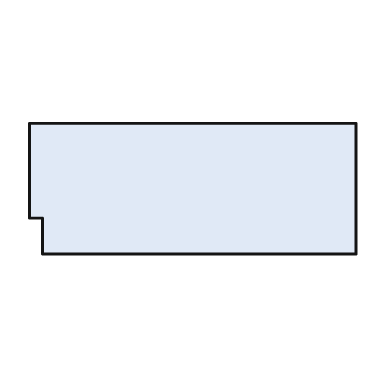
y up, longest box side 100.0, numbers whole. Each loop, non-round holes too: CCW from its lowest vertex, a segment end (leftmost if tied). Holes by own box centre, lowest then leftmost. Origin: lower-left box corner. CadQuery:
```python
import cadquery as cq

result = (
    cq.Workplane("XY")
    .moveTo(4.0, 0.0)
    .lineTo(100.0, 0.0)
    .lineTo(100.0, 40.0)
    .lineTo(0.0, 40.0)
    .lineTo(0.0, 11.0)
    .lineTo(4.0, 11.0)
    .close()
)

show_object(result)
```